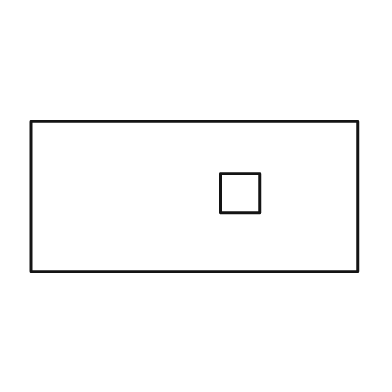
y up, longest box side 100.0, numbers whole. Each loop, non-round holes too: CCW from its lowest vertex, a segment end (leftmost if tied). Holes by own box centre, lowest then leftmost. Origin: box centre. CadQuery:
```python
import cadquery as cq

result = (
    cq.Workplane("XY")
    .moveTo(-50.0, -23.0)
    .lineTo(50.0, -23.0)
    .lineTo(50.0, 23.0)
    .lineTo(-50.0, 23.0)
    .close()
    .moveTo(8.0, -5.0)
    .lineTo(20.0, -5.0)
    .lineTo(20.0, 7.0)
    .lineTo(8.0, 7.0)
    .close()
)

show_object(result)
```